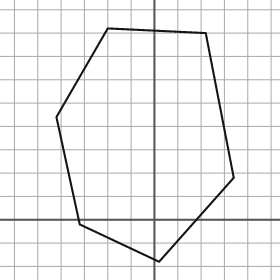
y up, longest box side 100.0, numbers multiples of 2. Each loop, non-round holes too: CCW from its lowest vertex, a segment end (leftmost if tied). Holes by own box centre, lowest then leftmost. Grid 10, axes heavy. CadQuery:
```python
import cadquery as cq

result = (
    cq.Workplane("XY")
    .moveTo(2.0, -18.0)
    .lineTo(34.0, 18.0)
    .lineTo(22.0, 80.0)
    .lineTo(-20.0, 82.0)
    .lineTo(-42.0, 44.0)
    .lineTo(-32.0, -2.0)
    .close()
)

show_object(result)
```